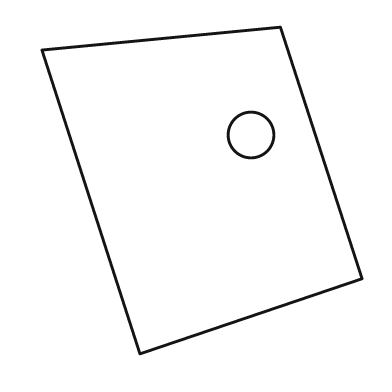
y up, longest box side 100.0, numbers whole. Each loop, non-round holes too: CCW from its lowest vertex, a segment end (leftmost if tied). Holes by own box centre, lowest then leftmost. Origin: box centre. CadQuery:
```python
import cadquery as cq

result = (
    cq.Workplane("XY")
    .moveTo(-19.0, -50.0)
    .lineTo(49.0, -27.0)
    .lineTo(24.0, 50.0)
    .lineTo(-49.0, 43.0)
    .close()
    .moveTo(15.0, 17.0)
    .circle(7.0)
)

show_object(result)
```